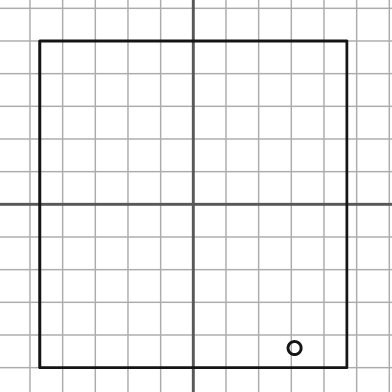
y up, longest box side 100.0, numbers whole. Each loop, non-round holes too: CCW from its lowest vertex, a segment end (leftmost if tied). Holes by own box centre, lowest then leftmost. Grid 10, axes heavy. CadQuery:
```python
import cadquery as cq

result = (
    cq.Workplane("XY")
    .moveTo(-47.0, -50.0)
    .lineTo(47.0, -50.0)
    .lineTo(47.0, 50.0)
    .lineTo(-47.0, 50.0)
    .close()
    .moveTo(31.0, -44.0)
    .circle(2.0)
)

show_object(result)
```